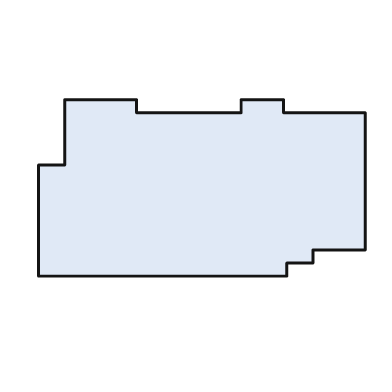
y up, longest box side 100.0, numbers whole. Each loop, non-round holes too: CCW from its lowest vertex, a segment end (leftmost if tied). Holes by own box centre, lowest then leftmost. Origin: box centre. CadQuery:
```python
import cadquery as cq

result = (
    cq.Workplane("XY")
    .moveTo(-50.0, -27.0)
    .lineTo(26.0, -27.0)
    .lineTo(26.0, -23.0)
    .lineTo(34.0, -23.0)
    .lineTo(34.0, -19.0)
    .lineTo(50.0, -19.0)
    .lineTo(50.0, 23.0)
    .lineTo(25.0, 23.0)
    .lineTo(25.0, 27.0)
    .lineTo(12.0, 27.0)
    .lineTo(12.0, 23.0)
    .lineTo(-20.0, 23.0)
    .lineTo(-20.0, 27.0)
    .lineTo(-42.0, 27.0)
    .lineTo(-42.0, 7.0)
    .lineTo(-50.0, 7.0)
    .close()
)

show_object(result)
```